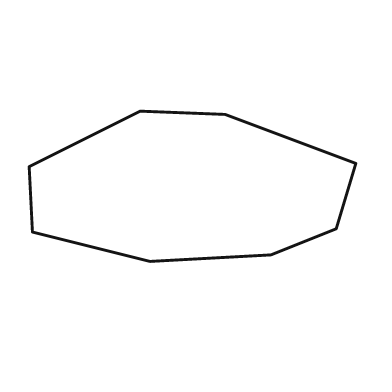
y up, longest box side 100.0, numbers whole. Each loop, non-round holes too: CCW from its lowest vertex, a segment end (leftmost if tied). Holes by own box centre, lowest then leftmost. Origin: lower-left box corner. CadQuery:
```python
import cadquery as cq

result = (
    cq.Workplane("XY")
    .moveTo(37.0, 0.0)
    .lineTo(74.0, 2.0)
    .lineTo(94.0, 10.0)
    .lineTo(100.0, 30.0)
    .lineTo(60.0, 45.0)
    .lineTo(34.0, 46.0)
    .lineTo(0.0, 29.0)
    .lineTo(1.0, 9.0)
    .close()
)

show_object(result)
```